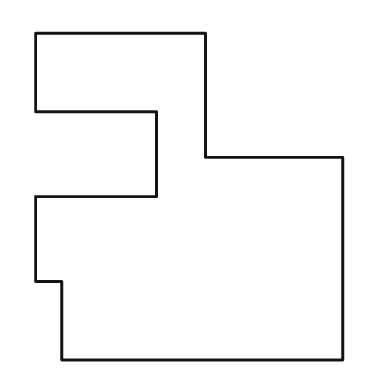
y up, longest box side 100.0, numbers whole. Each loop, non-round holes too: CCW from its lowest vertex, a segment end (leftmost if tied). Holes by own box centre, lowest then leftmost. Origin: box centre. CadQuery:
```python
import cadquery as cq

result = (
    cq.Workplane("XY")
    .moveTo(-39.0, -50.0)
    .lineTo(47.0, -50.0)
    .lineTo(47.0, 12.0)
    .lineTo(5.0, 12.0)
    .lineTo(5.0, 50.0)
    .lineTo(-47.0, 50.0)
    .lineTo(-47.0, 26.0)
    .lineTo(-10.0, 26.0)
    .lineTo(-10.0, 0.0)
    .lineTo(-47.0, 0.0)
    .lineTo(-47.0, -26.0)
    .lineTo(-39.0, -26.0)
    .close()
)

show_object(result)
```